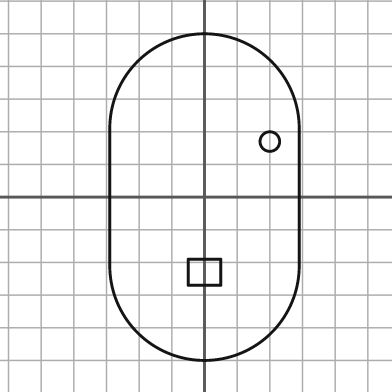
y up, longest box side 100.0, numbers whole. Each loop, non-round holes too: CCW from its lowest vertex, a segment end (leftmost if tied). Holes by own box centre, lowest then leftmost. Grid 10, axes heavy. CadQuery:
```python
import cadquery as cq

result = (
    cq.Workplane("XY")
    .moveTo(-29.0, -21.0)
    .threePointArc((0.0, -50.0), (29.0, -21.0))
    .lineTo(29.0, 21.0)
    .threePointArc((0.0, 50.0), (-29.0, 21.0))
    .close()
    .moveTo(-5.0, -27.0)
    .lineTo(5.0, -27.0)
    .lineTo(5.0, -19.0)
    .lineTo(-5.0, -19.0)
    .close()
    .moveTo(20.0, 17.0)
    .circle(3.0)
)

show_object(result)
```